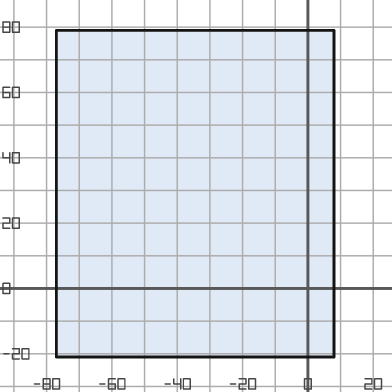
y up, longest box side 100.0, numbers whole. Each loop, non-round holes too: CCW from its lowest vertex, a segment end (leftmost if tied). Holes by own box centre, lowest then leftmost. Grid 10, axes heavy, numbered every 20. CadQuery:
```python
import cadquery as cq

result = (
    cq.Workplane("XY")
    .moveTo(-77.0, -21.0)
    .lineTo(8.0, -21.0)
    .lineTo(8.0, 79.0)
    .lineTo(-77.0, 79.0)
    .close()
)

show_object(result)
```